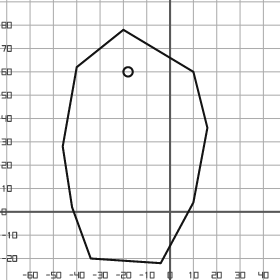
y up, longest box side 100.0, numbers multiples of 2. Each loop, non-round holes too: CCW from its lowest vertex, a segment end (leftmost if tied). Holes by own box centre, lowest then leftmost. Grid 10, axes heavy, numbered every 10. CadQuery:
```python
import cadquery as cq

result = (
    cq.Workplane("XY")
    .moveTo(-4.0, -22.0)
    .lineTo(10.0, 4.0)
    .lineTo(16.0, 36.0)
    .lineTo(10.0, 60.0)
    .lineTo(-20.0, 78.0)
    .lineTo(-40.0, 62.0)
    .lineTo(-46.0, 28.0)
    .lineTo(-42.0, 2.0)
    .lineTo(-34.0, -20.0)
    .close()
    .moveTo(-18.0, 60.0)
    .circle(2.0)
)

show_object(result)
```